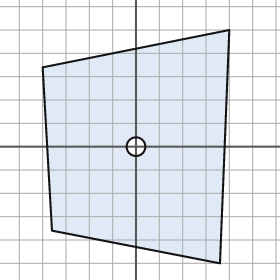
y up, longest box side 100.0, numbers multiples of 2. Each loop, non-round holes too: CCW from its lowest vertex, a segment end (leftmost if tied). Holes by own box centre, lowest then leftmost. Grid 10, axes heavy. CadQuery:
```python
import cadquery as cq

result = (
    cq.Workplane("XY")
    .moveTo(36.0, -50.0)
    .lineTo(40.0, 50.0)
    .lineTo(-40.0, 34.0)
    .lineTo(-36.0, -36.0)
    .close()
    .moveTo(0.0, 0.0)
    .circle(4.0)
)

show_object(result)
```